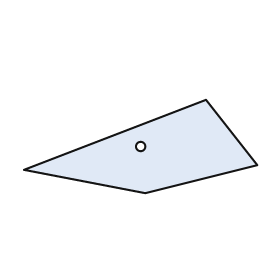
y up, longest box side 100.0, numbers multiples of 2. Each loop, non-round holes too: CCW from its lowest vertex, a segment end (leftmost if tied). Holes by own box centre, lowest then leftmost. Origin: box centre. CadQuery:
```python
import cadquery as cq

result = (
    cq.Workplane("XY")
    .moveTo(2.0, -20.0)
    .lineTo(50.0, -8.0)
    .lineTo(28.0, 20.0)
    .lineTo(-50.0, -10.0)
    .close()
    .moveTo(0.0, 0.0)
    .circle(2.0)
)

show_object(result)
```